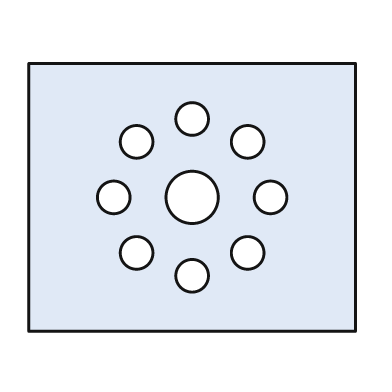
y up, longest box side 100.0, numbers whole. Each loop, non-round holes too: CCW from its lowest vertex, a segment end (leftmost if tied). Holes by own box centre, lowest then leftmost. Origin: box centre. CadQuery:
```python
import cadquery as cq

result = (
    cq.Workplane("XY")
    .moveTo(-50.0, -41.0)
    .lineTo(50.0, -41.0)
    .lineTo(50.0, 41.0)
    .lineTo(-50.0, 41.0)
    .close()
    .moveTo(0.0, -24.0)
    .circle(5.0)
    .moveTo(-17.0, -17.0)
    .circle(5.0)
    .moveTo(17.0, -17.0)
    .circle(5.0)
    .moveTo(-24.0, 0.0)
    .circle(5.0)
    .moveTo(0.0, 0.0)
    .circle(8.0)
    .moveTo(24.0, 0.0)
    .circle(5.0)
    .moveTo(-17.0, 17.0)
    .circle(5.0)
    .moveTo(17.0, 17.0)
    .circle(5.0)
    .moveTo(0.0, 24.0)
    .circle(5.0)
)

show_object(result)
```